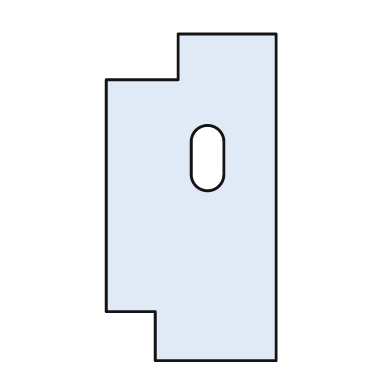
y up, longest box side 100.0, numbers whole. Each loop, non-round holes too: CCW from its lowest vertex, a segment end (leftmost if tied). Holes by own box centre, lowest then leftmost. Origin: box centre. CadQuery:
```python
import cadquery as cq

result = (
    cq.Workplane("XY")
    .moveTo(-11.0, -50.0)
    .lineTo(26.0, -50.0)
    .lineTo(26.0, 50.0)
    .lineTo(-4.0, 50.0)
    .lineTo(-4.0, 36.0)
    .lineTo(-26.0, 36.0)
    .lineTo(-26.0, -35.0)
    .lineTo(-11.0, -35.0)
    .close()
    .moveTo(0.0, 7.0)
    .threePointArc((5.0, 2.0), (10.0, 7.0))
    .lineTo(10.0, 17.0)
    .threePointArc((5.0, 22.0), (0.0, 17.0))
    .close()
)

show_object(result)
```